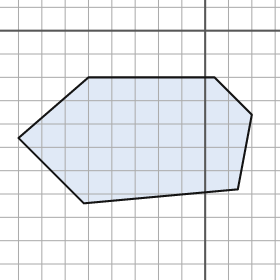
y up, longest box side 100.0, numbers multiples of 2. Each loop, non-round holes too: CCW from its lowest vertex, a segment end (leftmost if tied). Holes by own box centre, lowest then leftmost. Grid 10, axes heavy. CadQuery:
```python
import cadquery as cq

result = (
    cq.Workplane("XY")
    .moveTo(-52.0, -74.0)
    .lineTo(14.0, -68.0)
    .lineTo(20.0, -36.0)
    .lineTo(4.0, -20.0)
    .lineTo(-50.0, -20.0)
    .lineTo(-80.0, -46.0)
    .close()
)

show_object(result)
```